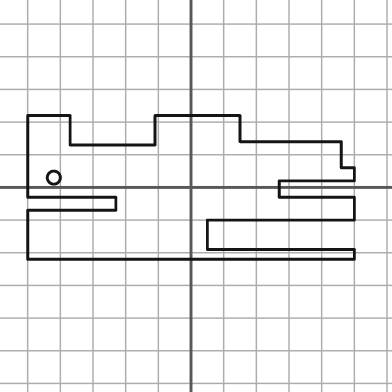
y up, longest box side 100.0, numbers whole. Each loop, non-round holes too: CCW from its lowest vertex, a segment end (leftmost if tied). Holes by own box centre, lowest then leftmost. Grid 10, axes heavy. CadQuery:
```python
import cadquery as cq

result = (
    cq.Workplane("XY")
    .moveTo(-50.0, -22.0)
    .lineTo(50.0, -22.0)
    .lineTo(50.0, -19.0)
    .lineTo(5.0, -19.0)
    .lineTo(5.0, -10.0)
    .lineTo(50.0, -10.0)
    .lineTo(50.0, -3.0)
    .lineTo(27.0, -3.0)
    .lineTo(27.0, 2.0)
    .lineTo(50.0, 2.0)
    .lineTo(50.0, 6.0)
    .lineTo(46.0, 6.0)
    .lineTo(46.0, 14.0)
    .lineTo(15.0, 14.0)
    .lineTo(15.0, 22.0)
    .lineTo(-11.0, 22.0)
    .lineTo(-11.0, 13.0)
    .lineTo(-37.0, 13.0)
    .lineTo(-37.0, 22.0)
    .lineTo(-50.0, 22.0)
    .lineTo(-50.0, -3.0)
    .lineTo(-23.0, -3.0)
    .lineTo(-23.0, -7.0)
    .lineTo(-50.0, -7.0)
    .close()
    .moveTo(-42.0, 3.0)
    .circle(2.0)
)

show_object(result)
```